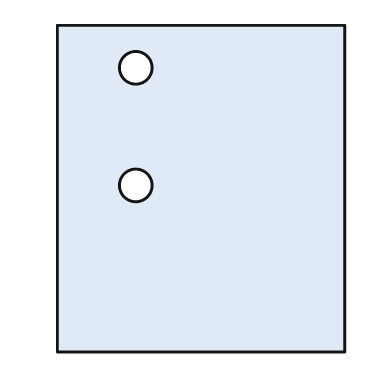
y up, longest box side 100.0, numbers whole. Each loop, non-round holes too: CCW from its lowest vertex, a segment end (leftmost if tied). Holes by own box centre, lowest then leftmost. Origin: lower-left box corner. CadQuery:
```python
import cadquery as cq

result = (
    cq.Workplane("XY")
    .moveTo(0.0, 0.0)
    .lineTo(88.0, 0.0)
    .lineTo(88.0, 100.0)
    .lineTo(0.0, 100.0)
    .close()
    .moveTo(24.0, 51.0)
    .circle(5.0)
    .moveTo(24.0, 87.0)
    .circle(5.0)
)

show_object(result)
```